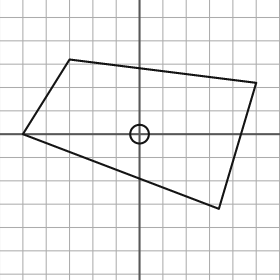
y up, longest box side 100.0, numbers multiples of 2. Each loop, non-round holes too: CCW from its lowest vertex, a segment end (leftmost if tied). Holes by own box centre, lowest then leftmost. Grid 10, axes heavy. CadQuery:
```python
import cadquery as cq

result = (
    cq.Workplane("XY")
    .moveTo(34.0, -32.0)
    .lineTo(50.0, 22.0)
    .lineTo(-30.0, 32.0)
    .lineTo(-50.0, 0.0)
    .close()
    .moveTo(0.0, 0.0)
    .circle(4.0)
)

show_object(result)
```